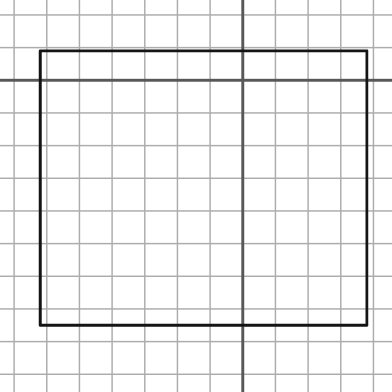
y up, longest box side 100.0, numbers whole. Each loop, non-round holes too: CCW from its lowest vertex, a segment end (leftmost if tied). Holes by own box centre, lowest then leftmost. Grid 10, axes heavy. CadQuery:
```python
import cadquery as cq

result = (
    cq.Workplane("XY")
    .moveTo(-62.0, -75.0)
    .lineTo(38.0, -75.0)
    .lineTo(38.0, 9.0)
    .lineTo(-62.0, 9.0)
    .close()
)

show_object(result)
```